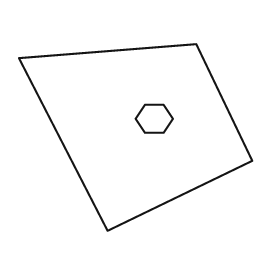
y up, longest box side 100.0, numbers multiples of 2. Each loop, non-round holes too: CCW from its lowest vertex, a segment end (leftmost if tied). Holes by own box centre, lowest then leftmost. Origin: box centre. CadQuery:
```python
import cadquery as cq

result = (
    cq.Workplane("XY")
    .moveTo(-12.0, -40.0)
    .lineTo(50.0, -10.0)
    .lineTo(26.0, 40.0)
    .lineTo(-50.0, 34.0)
    .close()
    .moveTo(4.0, 2.0)
    .lineTo(12.0, 2.0)
    .lineTo(16.0, 8.0)
    .lineTo(12.0, 14.0)
    .lineTo(4.0, 14.0)
    .lineTo(0.0, 8.0)
    .close()
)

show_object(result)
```